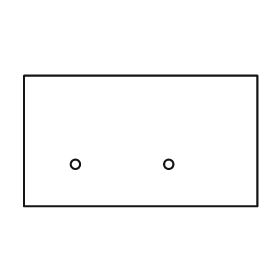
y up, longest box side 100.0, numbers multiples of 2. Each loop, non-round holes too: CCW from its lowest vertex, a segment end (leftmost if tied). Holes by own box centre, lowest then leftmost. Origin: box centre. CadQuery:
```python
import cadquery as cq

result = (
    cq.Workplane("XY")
    .moveTo(-50.0, -28.0)
    .lineTo(50.0, -28.0)
    .lineTo(50.0, 28.0)
    .lineTo(-50.0, 28.0)
    .close()
    .moveTo(-28.0, -10.0)
    .circle(2.0)
    .moveTo(12.0, -10.0)
    .circle(2.0)
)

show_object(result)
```